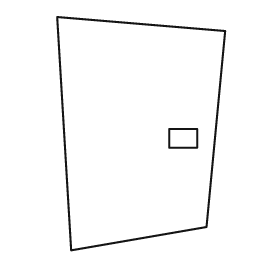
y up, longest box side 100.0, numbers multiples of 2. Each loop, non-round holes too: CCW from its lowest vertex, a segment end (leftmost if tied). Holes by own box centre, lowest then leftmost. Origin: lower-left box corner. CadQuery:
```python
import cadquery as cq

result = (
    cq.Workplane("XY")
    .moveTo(6.0, 0.0)
    .lineTo(64.0, 10.0)
    .lineTo(72.0, 94.0)
    .lineTo(0.0, 100.0)
    .close()
    .moveTo(48.0, 44.0)
    .lineTo(60.0, 44.0)
    .lineTo(60.0, 52.0)
    .lineTo(48.0, 52.0)
    .close()
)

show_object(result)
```